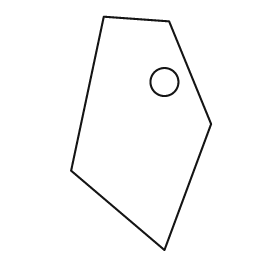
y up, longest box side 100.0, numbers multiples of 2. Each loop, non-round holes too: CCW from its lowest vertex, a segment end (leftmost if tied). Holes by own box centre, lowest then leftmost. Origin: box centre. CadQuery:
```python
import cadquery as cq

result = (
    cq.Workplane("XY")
    .moveTo(10.0, -50.0)
    .lineTo(30.0, 4.0)
    .lineTo(12.0, 48.0)
    .lineTo(-16.0, 50.0)
    .lineTo(-30.0, -16.0)
    .close()
    .moveTo(10.0, 22.0)
    .circle(6.0)
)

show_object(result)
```